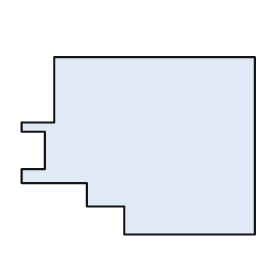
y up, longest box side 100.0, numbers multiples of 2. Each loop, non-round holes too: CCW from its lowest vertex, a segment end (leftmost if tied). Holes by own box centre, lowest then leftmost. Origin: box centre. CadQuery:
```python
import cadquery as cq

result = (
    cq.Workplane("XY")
    .moveTo(-6.0, -38.0)
    .lineTo(50.0, -38.0)
    .lineTo(50.0, 38.0)
    .lineTo(-36.0, 38.0)
    .lineTo(-36.0, 10.0)
    .lineTo(-50.0, 10.0)
    .lineTo(-50.0, 6.0)
    .lineTo(-40.0, 6.0)
    .lineTo(-40.0, -10.0)
    .lineTo(-50.0, -10.0)
    .lineTo(-50.0, -16.0)
    .lineTo(-22.0, -16.0)
    .lineTo(-22.0, -26.0)
    .lineTo(-6.0, -26.0)
    .close()
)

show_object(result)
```